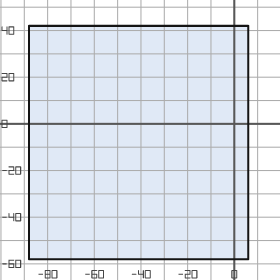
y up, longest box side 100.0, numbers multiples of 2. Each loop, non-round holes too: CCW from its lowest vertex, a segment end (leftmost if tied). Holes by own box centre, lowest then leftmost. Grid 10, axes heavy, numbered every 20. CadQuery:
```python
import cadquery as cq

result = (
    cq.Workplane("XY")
    .moveTo(-88.0, -58.0)
    .lineTo(6.0, -58.0)
    .lineTo(6.0, 42.0)
    .lineTo(-88.0, 42.0)
    .close()
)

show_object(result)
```